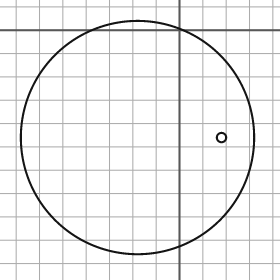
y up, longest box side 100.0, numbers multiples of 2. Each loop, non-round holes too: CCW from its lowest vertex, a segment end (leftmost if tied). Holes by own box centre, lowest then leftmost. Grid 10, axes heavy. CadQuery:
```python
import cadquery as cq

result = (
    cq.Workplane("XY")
    .moveTo(-18.0, -46.0)
    .circle(50.0)
    .moveTo(18.0, -46.0)
    .circle(2.0)
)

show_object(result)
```